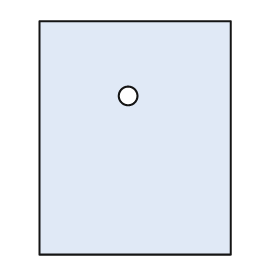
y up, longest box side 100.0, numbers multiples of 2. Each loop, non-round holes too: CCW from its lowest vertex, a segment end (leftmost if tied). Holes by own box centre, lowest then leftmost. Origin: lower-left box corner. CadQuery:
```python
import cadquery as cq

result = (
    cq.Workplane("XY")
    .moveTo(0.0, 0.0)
    .lineTo(82.0, 0.0)
    .lineTo(82.0, 100.0)
    .lineTo(0.0, 100.0)
    .close()
    .moveTo(38.0, 68.0)
    .circle(4.0)
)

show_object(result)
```